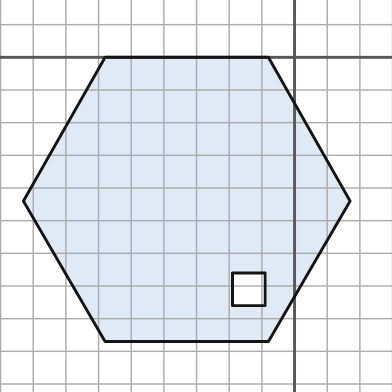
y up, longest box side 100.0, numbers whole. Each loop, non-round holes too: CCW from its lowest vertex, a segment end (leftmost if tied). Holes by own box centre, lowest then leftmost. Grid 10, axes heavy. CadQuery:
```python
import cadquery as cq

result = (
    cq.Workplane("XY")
    .moveTo(-58.0, -87.0)
    .lineTo(-8.0, -87.0)
    .lineTo(17.0, -44.0)
    .lineTo(-8.0, 0.0)
    .lineTo(-58.0, 0.0)
    .lineTo(-83.0, -44.0)
    .close()
    .moveTo(-19.0, -76.0)
    .lineTo(-9.0, -76.0)
    .lineTo(-9.0, -66.0)
    .lineTo(-19.0, -66.0)
    .close()
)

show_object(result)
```